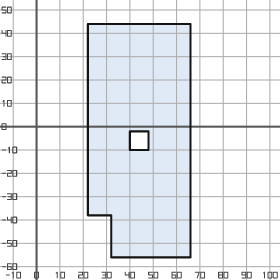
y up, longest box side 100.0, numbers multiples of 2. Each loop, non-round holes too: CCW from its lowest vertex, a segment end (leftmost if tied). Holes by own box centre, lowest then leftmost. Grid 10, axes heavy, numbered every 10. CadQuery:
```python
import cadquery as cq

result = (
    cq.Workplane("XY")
    .moveTo(32.0, -56.0)
    .lineTo(66.0, -56.0)
    .lineTo(66.0, 44.0)
    .lineTo(22.0, 44.0)
    .lineTo(22.0, -38.0)
    .lineTo(32.0, -38.0)
    .close()
    .moveTo(40.0, -10.0)
    .lineTo(48.0, -10.0)
    .lineTo(48.0, -2.0)
    .lineTo(40.0, -2.0)
    .close()
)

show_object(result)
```